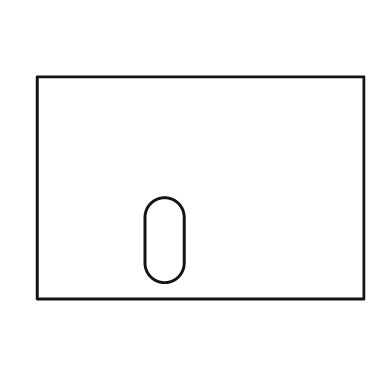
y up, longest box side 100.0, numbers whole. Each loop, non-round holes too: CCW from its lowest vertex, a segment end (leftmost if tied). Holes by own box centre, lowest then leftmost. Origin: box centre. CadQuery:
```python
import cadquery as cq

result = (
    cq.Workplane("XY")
    .moveTo(-50.0, -34.0)
    .lineTo(50.0, -34.0)
    .lineTo(50.0, 34.0)
    .lineTo(-50.0, 34.0)
    .close()
    .moveTo(-17.0, -23.0)
    .threePointArc((-11.0, -29.0), (-5.0, -23.0))
    .lineTo(-5.0, -9.0)
    .threePointArc((-11.0, -3.0), (-17.0, -9.0))
    .close()
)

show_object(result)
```